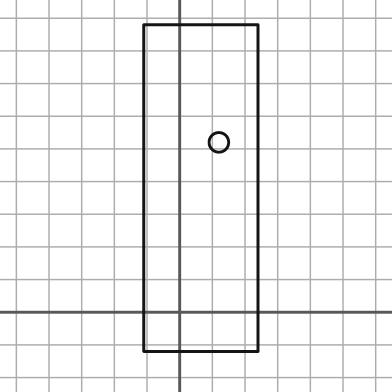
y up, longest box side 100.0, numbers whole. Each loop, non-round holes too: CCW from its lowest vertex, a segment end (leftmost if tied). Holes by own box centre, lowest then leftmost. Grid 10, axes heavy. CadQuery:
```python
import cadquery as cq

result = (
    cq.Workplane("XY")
    .moveTo(-11.0, -12.0)
    .lineTo(24.0, -12.0)
    .lineTo(24.0, 88.0)
    .lineTo(-11.0, 88.0)
    .close()
    .moveTo(12.0, 52.0)
    .circle(3.0)
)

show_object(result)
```